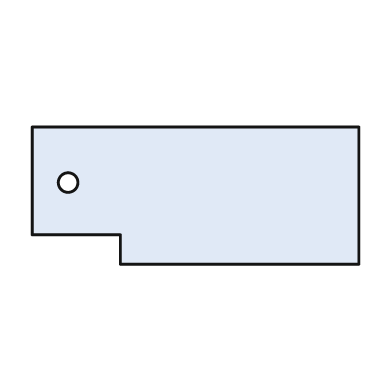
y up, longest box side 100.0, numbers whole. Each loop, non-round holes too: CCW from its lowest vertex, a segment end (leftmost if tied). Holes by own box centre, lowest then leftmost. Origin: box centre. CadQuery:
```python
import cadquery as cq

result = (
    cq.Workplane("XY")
    .moveTo(-23.0, -21.0)
    .lineTo(50.0, -21.0)
    .lineTo(50.0, 21.0)
    .lineTo(-50.0, 21.0)
    .lineTo(-50.0, -12.0)
    .lineTo(-23.0, -12.0)
    .close()
    .moveTo(-39.0, 4.0)
    .circle(3.0)
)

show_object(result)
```